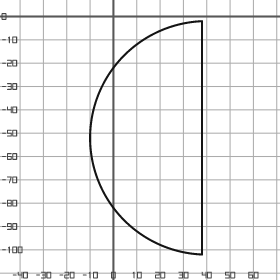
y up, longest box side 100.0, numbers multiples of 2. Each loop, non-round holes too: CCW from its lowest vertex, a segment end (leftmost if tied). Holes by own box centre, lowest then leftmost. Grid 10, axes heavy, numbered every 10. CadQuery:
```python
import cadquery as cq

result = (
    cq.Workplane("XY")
    .moveTo(38.0, -102.0)
    .lineTo(38.0, -2.0)
    .threePointArc((-10.0, -52.0), (38.0, -102.0))
    .close()
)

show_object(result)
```